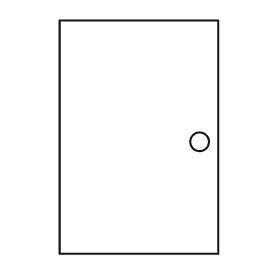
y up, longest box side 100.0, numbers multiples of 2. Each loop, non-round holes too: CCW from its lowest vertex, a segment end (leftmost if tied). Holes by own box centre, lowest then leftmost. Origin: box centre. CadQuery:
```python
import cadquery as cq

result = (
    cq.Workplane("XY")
    .moveTo(-34.0, -50.0)
    .lineTo(34.0, -50.0)
    .lineTo(34.0, 50.0)
    .lineTo(-34.0, 50.0)
    .close()
    .moveTo(26.0, -2.0)
    .circle(4.0)
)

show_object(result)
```